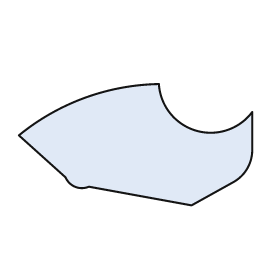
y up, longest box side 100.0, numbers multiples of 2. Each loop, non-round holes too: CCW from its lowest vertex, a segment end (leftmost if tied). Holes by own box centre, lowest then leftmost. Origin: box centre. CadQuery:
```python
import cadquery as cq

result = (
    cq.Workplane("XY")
    .moveTo(24.0, -26.0)
    .lineTo(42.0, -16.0)
    .threePointArc((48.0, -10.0), (50.0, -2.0))
    .lineTo(50.0, 14.0)
    .threePointArc((26.0, 6.0), (10.0, 26.0))
    .threePointArc((-22.0, 20.0), (-50.0, 4.0))
    .lineTo(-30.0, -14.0)
    .threePointArc((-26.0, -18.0), (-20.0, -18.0))
    .close()
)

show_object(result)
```